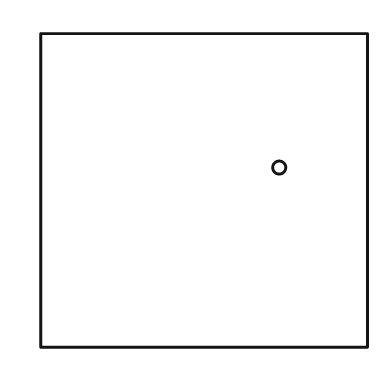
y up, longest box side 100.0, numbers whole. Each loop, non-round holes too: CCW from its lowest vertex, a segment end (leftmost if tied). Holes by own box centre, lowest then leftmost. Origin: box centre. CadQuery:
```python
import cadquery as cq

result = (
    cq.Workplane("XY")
    .moveTo(-50.0, -48.0)
    .lineTo(50.0, -48.0)
    .lineTo(50.0, 48.0)
    .lineTo(-50.0, 48.0)
    .close()
    .moveTo(23.0, 7.0)
    .circle(2.0)
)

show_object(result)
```